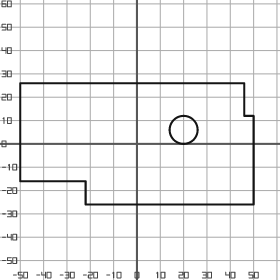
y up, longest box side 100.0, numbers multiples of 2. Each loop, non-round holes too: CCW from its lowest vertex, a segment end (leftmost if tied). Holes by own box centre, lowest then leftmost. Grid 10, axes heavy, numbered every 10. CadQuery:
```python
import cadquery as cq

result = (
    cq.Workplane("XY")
    .moveTo(-22.0, -26.0)
    .lineTo(50.0, -26.0)
    .lineTo(50.0, 12.0)
    .lineTo(46.0, 12.0)
    .lineTo(46.0, 26.0)
    .lineTo(-50.0, 26.0)
    .lineTo(-50.0, -16.0)
    .lineTo(-22.0, -16.0)
    .close()
    .moveTo(20.0, 6.0)
    .circle(6.0)
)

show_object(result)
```